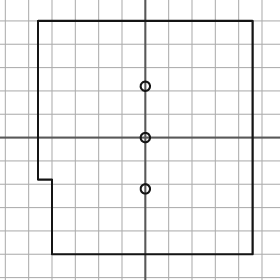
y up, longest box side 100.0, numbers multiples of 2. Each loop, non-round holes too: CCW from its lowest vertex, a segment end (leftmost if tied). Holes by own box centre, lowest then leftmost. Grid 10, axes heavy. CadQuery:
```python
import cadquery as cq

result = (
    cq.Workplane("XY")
    .moveTo(-40.0, -50.0)
    .lineTo(46.0, -50.0)
    .lineTo(46.0, 50.0)
    .lineTo(-46.0, 50.0)
    .lineTo(-46.0, -18.0)
    .lineTo(-40.0, -18.0)
    .close()
    .moveTo(0.0, -22.0)
    .circle(2.0)
    .moveTo(0.0, 0.0)
    .circle(2.0)
    .moveTo(0.0, 22.0)
    .circle(2.0)
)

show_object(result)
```